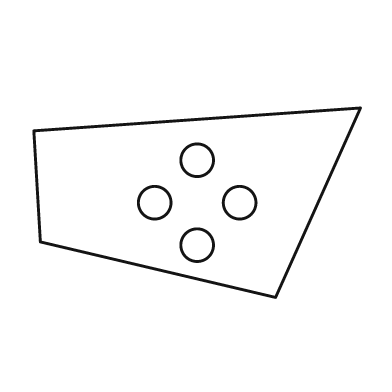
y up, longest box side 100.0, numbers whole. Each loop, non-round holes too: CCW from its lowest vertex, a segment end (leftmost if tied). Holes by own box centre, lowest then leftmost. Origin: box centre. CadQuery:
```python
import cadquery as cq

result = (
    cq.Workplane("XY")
    .moveTo(24.0, -29.0)
    .lineTo(50.0, 29.0)
    .lineTo(-50.0, 22.0)
    .lineTo(-48.0, -12.0)
    .close()
    .moveTo(0.0, -13.0)
    .circle(5.0)
    .moveTo(-13.0, 0.0)
    .circle(5.0)
    .moveTo(13.0, 0.0)
    .circle(5.0)
    .moveTo(0.0, 13.0)
    .circle(5.0)
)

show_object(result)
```